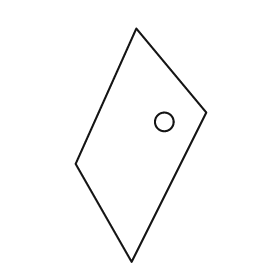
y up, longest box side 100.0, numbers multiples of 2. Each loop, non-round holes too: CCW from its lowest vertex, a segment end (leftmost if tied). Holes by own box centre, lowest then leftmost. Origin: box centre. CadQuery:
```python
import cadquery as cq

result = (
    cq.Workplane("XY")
    .moveTo(-4.0, -50.0)
    .lineTo(28.0, 14.0)
    .lineTo(-2.0, 50.0)
    .lineTo(-28.0, -8.0)
    .close()
    .moveTo(10.0, 10.0)
    .circle(4.0)
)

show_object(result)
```